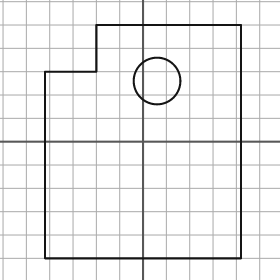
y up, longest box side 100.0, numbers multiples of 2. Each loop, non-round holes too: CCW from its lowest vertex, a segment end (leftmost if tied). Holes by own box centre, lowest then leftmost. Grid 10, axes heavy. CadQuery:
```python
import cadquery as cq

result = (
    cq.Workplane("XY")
    .moveTo(-42.0, -50.0)
    .lineTo(42.0, -50.0)
    .lineTo(42.0, 50.0)
    .lineTo(-20.0, 50.0)
    .lineTo(-20.0, 30.0)
    .lineTo(-42.0, 30.0)
    .close()
    .moveTo(6.0, 26.0)
    .circle(10.0)
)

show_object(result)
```